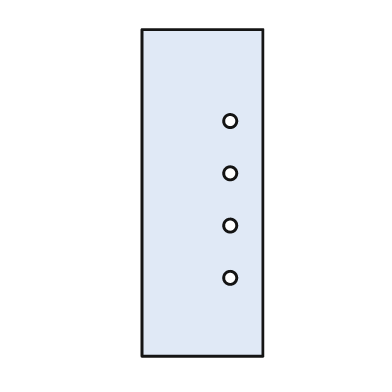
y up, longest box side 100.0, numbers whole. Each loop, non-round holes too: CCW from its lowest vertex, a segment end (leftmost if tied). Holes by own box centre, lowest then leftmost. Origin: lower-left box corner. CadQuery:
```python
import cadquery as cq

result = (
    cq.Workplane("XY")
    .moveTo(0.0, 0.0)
    .lineTo(37.0, 0.0)
    .lineTo(37.0, 100.0)
    .lineTo(0.0, 100.0)
    .close()
    .moveTo(27.0, 24.0)
    .circle(2.0)
    .moveTo(27.0, 40.0)
    .circle(2.0)
    .moveTo(27.0, 56.0)
    .circle(2.0)
    .moveTo(27.0, 72.0)
    .circle(2.0)
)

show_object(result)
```